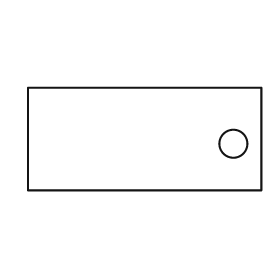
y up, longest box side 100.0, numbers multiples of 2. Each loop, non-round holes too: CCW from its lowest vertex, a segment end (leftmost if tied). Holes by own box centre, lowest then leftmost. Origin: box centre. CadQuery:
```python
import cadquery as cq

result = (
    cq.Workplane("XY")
    .moveTo(-50.0, -22.0)
    .lineTo(50.0, -22.0)
    .lineTo(50.0, 22.0)
    .lineTo(-50.0, 22.0)
    .close()
    .moveTo(38.0, -2.0)
    .circle(6.0)
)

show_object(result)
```